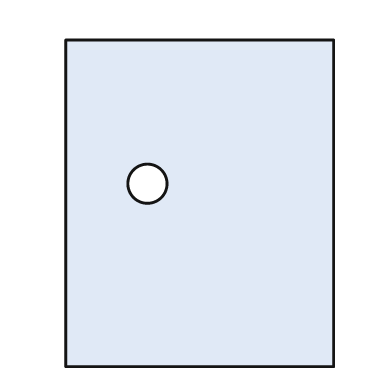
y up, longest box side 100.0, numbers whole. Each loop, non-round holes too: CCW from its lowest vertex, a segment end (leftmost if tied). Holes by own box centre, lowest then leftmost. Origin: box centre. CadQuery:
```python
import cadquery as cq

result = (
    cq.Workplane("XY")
    .moveTo(-41.0, -50.0)
    .lineTo(41.0, -50.0)
    .lineTo(41.0, 50.0)
    .lineTo(-41.0, 50.0)
    .close()
    .moveTo(-16.0, 6.0)
    .circle(6.0)
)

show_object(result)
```